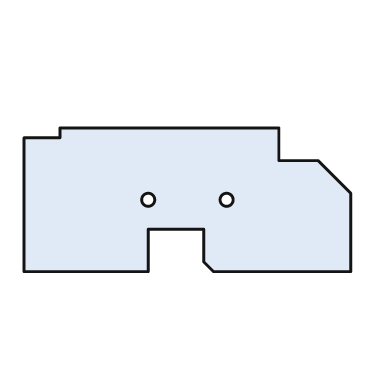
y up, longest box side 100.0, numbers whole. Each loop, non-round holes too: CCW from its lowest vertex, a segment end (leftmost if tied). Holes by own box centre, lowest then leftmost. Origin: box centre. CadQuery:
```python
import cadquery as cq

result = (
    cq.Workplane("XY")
    .moveTo(-50.0, -22.0)
    .lineTo(-12.0, -22.0)
    .lineTo(-12.0, -9.0)
    .lineTo(5.0, -9.0)
    .lineTo(5.0, -19.0)
    .lineTo(8.0, -22.0)
    .lineTo(50.0, -22.0)
    .lineTo(50.0, 2.0)
    .lineTo(40.0, 12.0)
    .lineTo(28.0, 12.0)
    .lineTo(28.0, 22.0)
    .lineTo(-39.0, 22.0)
    .lineTo(-39.0, 19.0)
    .lineTo(-50.0, 19.0)
    .close()
    .moveTo(-12.0, 0.0)
    .circle(2.0)
    .moveTo(12.0, 0.0)
    .circle(2.0)
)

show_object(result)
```